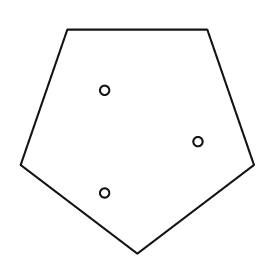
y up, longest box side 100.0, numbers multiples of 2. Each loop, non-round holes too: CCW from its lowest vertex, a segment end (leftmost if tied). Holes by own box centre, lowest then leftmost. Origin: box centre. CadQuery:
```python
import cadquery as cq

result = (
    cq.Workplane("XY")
    .moveTo(0.0, -48.0)
    .lineTo(50.0, -10.0)
    .lineTo(30.0, 48.0)
    .lineTo(-30.0, 48.0)
    .lineTo(-50.0, -10.0)
    .close()
    .moveTo(-14.0, -22.0)
    .circle(2.0)
    .moveTo(26.0, 0.0)
    .circle(2.0)
    .moveTo(-14.0, 22.0)
    .circle(2.0)
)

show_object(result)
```